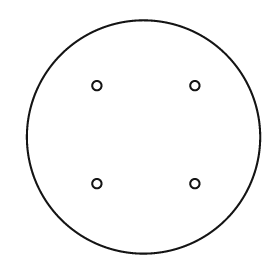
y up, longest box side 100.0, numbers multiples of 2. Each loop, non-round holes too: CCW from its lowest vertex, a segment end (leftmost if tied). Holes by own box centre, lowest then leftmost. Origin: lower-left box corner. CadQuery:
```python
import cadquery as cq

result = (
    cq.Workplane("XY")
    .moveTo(50.0, 50.0)
    .circle(50.0)
    .moveTo(30.0, 30.0)
    .circle(2.0)
    .moveTo(72.0, 30.0)
    .circle(2.0)
    .moveTo(30.0, 72.0)
    .circle(2.0)
    .moveTo(72.0, 72.0)
    .circle(2.0)
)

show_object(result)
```